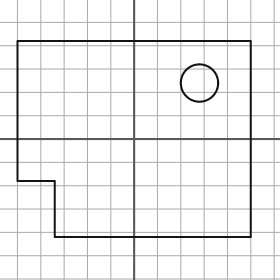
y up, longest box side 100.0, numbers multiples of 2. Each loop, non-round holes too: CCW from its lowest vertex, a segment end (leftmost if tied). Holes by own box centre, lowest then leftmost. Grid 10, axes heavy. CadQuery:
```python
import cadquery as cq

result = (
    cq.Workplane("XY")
    .moveTo(-34.0, -42.0)
    .lineTo(50.0, -42.0)
    .lineTo(50.0, 42.0)
    .lineTo(-50.0, 42.0)
    .lineTo(-50.0, -18.0)
    .lineTo(-34.0, -18.0)
    .close()
    .moveTo(28.0, 24.0)
    .circle(8.0)
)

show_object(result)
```